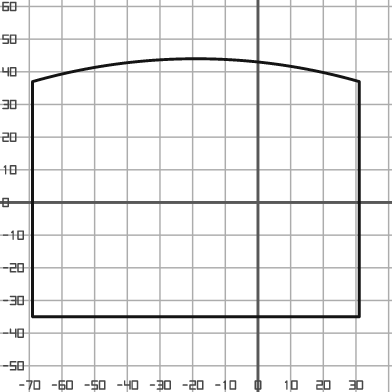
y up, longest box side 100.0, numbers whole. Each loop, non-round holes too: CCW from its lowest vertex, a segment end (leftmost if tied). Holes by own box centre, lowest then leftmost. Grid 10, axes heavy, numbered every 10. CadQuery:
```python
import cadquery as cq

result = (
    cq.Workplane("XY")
    .moveTo(-69.0, -35.0)
    .lineTo(31.0, -35.0)
    .lineTo(31.0, 37.0)
    .threePointArc((-19.0, 44.0), (-69.0, 37.0))
    .close()
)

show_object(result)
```